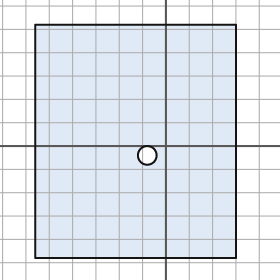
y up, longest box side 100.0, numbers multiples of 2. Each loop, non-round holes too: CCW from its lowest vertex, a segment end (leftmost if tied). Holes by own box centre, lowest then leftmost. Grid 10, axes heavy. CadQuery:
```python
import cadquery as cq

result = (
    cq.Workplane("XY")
    .moveTo(-56.0, -48.0)
    .lineTo(30.0, -48.0)
    .lineTo(30.0, 52.0)
    .lineTo(-56.0, 52.0)
    .close()
    .moveTo(-8.0, -4.0)
    .circle(4.0)
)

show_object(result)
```